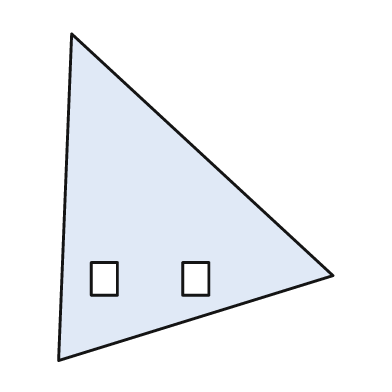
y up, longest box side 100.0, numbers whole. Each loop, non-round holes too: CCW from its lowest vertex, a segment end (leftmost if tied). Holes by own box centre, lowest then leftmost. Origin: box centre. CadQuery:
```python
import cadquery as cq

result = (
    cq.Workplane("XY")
    .moveTo(-42.0, -50.0)
    .lineTo(42.0, -24.0)
    .lineTo(-38.0, 50.0)
    .close()
    .moveTo(-32.0, -30.0)
    .lineTo(-24.0, -30.0)
    .lineTo(-24.0, -20.0)
    .lineTo(-32.0, -20.0)
    .close()
    .moveTo(-4.0, -30.0)
    .lineTo(4.0, -30.0)
    .lineTo(4.0, -20.0)
    .lineTo(-4.0, -20.0)
    .close()
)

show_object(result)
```